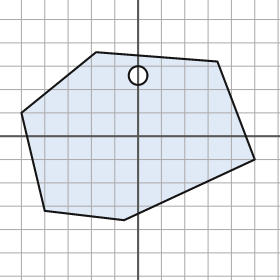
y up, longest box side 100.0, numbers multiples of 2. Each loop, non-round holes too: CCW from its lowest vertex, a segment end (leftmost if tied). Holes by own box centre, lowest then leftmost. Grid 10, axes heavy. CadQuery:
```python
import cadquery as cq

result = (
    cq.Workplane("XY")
    .moveTo(-6.0, -36.0)
    .lineTo(50.0, -10.0)
    .lineTo(34.0, 32.0)
    .lineTo(-18.0, 36.0)
    .lineTo(-50.0, 10.0)
    .lineTo(-40.0, -32.0)
    .close()
    .moveTo(0.0, 26.0)
    .circle(4.0)
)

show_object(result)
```